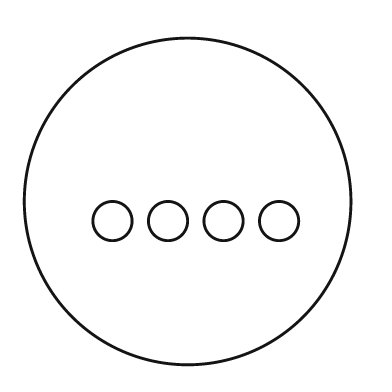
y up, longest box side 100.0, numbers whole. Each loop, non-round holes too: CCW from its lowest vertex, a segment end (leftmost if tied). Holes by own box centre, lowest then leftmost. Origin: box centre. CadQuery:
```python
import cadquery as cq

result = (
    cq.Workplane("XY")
    .moveTo(0.0, 0.0)
    .circle(50.0)
    .moveTo(-23.0, -6.0)
    .circle(6.0)
    .moveTo(-6.0, -6.0)
    .circle(6.0)
    .moveTo(11.0, -6.0)
    .circle(6.0)
    .moveTo(28.0, -6.0)
    .circle(6.0)
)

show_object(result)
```